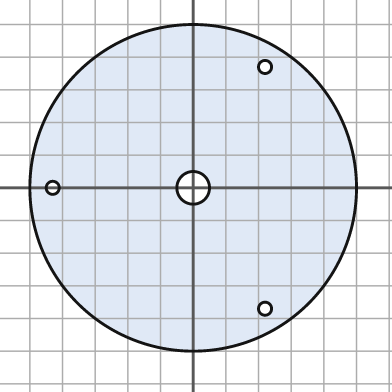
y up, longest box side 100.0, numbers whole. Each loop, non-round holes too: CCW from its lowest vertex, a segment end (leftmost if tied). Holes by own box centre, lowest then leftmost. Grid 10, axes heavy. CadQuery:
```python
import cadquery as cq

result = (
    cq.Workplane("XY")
    .moveTo(0.0, 0.0)
    .circle(50.0)
    .moveTo(22.0, -37.0)
    .circle(2.0)
    .moveTo(-43.0, 0.0)
    .circle(2.0)
    .moveTo(0.0, 0.0)
    .circle(5.0)
    .moveTo(22.0, 37.0)
    .circle(2.0)
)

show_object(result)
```